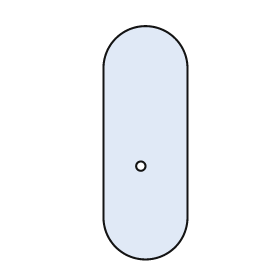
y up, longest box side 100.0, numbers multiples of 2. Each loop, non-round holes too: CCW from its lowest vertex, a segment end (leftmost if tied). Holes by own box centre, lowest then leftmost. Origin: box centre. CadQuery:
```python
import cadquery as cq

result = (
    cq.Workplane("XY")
    .moveTo(-18.0, -32.0)
    .threePointArc((0.0, -50.0), (18.0, -32.0))
    .lineTo(18.0, 32.0)
    .threePointArc((0.0, 50.0), (-18.0, 32.0))
    .close()
    .moveTo(-2.0, -10.0)
    .circle(2.0)
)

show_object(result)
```